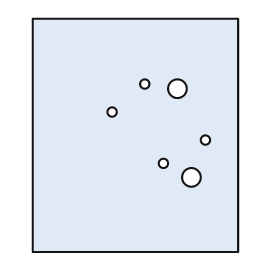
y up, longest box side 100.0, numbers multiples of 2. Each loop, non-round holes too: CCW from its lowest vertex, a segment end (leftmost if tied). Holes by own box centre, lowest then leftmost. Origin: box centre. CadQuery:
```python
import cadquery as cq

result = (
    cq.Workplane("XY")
    .moveTo(-44.0, -50.0)
    .lineTo(44.0, -50.0)
    .lineTo(44.0, 50.0)
    .lineTo(-44.0, 50.0)
    .close()
    .moveTo(24.0, -18.0)
    .circle(4.0)
    .moveTo(12.0, -12.0)
    .circle(2.0)
    .moveTo(30.0, -2.0)
    .circle(2.0)
    .moveTo(-10.0, 10.0)
    .circle(2.0)
    .moveTo(18.0, 20.0)
    .circle(4.0)
    .moveTo(4.0, 22.0)
    .circle(2.0)
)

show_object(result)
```